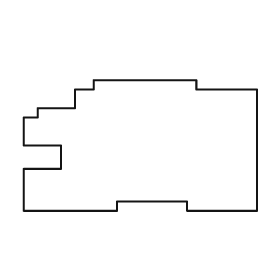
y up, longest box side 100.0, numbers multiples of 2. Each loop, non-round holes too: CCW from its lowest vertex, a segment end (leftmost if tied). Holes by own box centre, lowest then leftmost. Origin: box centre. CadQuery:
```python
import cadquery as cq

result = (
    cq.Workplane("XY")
    .moveTo(-50.0, -28.0)
    .lineTo(-10.0, -28.0)
    .lineTo(-10.0, -24.0)
    .lineTo(20.0, -24.0)
    .lineTo(20.0, -28.0)
    .lineTo(50.0, -28.0)
    .lineTo(50.0, 24.0)
    .lineTo(24.0, 24.0)
    .lineTo(24.0, 28.0)
    .lineTo(-20.0, 28.0)
    .lineTo(-20.0, 24.0)
    .lineTo(-28.0, 24.0)
    .lineTo(-28.0, 16.0)
    .lineTo(-44.0, 16.0)
    .lineTo(-44.0, 12.0)
    .lineTo(-50.0, 12.0)
    .lineTo(-50.0, 0.0)
    .lineTo(-34.0, 0.0)
    .lineTo(-34.0, -10.0)
    .lineTo(-50.0, -10.0)
    .close()
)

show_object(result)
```